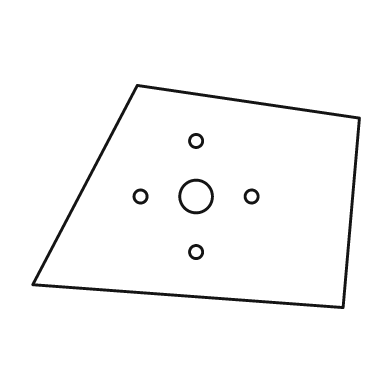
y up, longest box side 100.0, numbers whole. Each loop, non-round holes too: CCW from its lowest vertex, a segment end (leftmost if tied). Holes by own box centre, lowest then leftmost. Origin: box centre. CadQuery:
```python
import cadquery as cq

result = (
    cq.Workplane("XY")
    .moveTo(45.0, -34.0)
    .lineTo(50.0, 24.0)
    .lineTo(-18.0, 34.0)
    .lineTo(-50.0, -27.0)
    .close()
    .moveTo(0.0, -17.0)
    .circle(2.0)
    .moveTo(-17.0, 0.0)
    .circle(2.0)
    .moveTo(0.0, 0.0)
    .circle(5.0)
    .moveTo(17.0, 0.0)
    .circle(2.0)
    .moveTo(0.0, 17.0)
    .circle(2.0)
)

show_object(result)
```